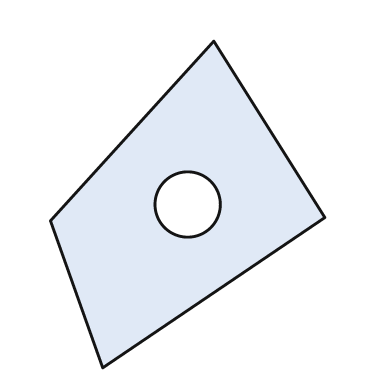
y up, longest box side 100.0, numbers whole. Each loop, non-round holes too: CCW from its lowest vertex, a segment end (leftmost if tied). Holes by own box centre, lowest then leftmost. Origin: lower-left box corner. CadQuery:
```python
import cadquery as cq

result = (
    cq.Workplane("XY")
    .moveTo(16.0, 0.0)
    .lineTo(84.0, 46.0)
    .lineTo(50.0, 100.0)
    .lineTo(0.0, 45.0)
    .close()
    .moveTo(42.0, 50.0)
    .circle(10.0)
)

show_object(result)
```